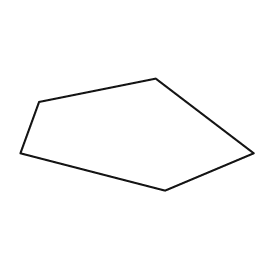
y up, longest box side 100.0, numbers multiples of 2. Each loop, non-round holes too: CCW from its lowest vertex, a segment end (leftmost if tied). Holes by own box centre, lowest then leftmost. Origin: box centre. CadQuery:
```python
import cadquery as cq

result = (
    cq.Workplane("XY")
    .moveTo(12.0, -24.0)
    .lineTo(50.0, -8.0)
    .lineTo(8.0, 24.0)
    .lineTo(-42.0, 14.0)
    .lineTo(-50.0, -8.0)
    .close()
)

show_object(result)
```